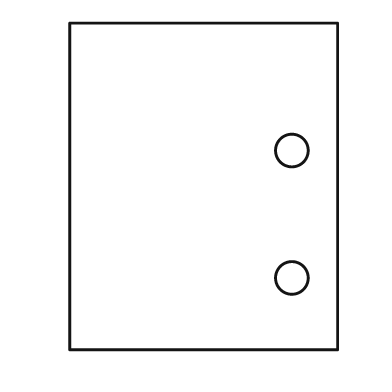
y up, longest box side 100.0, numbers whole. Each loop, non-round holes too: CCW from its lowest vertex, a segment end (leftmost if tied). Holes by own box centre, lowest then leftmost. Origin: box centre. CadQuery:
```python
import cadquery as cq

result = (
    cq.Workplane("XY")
    .moveTo(-41.0, -50.0)
    .lineTo(41.0, -50.0)
    .lineTo(41.0, 50.0)
    .lineTo(-41.0, 50.0)
    .close()
    .moveTo(27.0, -28.0)
    .circle(5.0)
    .moveTo(27.0, 11.0)
    .circle(5.0)
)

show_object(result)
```